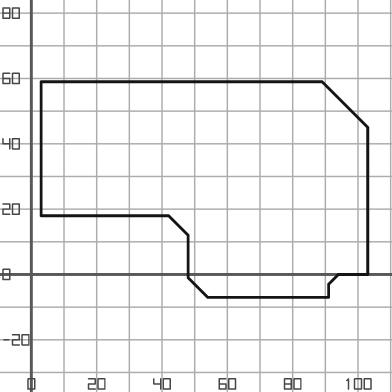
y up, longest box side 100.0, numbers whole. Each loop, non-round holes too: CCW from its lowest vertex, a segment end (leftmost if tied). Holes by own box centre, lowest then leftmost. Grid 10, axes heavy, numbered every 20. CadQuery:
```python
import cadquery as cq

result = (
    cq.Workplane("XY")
    .moveTo(54.0, -7.0)
    .lineTo(91.0, -7.0)
    .lineTo(91.0, -3.0)
    .lineTo(94.0, 0.0)
    .lineTo(103.0, 0.0)
    .lineTo(103.0, 45.0)
    .lineTo(89.0, 59.0)
    .lineTo(3.0, 59.0)
    .lineTo(3.0, 18.0)
    .lineTo(42.0, 18.0)
    .lineTo(48.0, 12.0)
    .lineTo(48.0, -1.0)
    .close()
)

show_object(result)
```